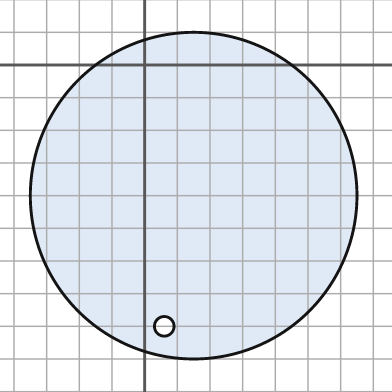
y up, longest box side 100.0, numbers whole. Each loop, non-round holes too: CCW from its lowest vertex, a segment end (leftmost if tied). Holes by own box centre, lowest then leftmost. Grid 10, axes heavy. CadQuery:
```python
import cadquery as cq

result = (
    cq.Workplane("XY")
    .moveTo(15.0, -40.0)
    .circle(50.0)
    .moveTo(6.0, -80.0)
    .circle(3.0)
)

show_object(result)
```